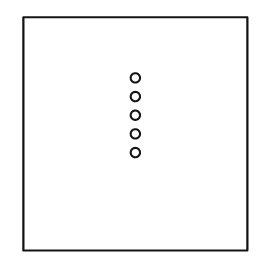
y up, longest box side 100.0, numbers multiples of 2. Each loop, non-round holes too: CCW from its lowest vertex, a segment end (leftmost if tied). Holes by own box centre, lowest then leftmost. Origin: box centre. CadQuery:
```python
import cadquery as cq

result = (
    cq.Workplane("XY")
    .moveTo(-48.0, -50.0)
    .lineTo(48.0, -50.0)
    .lineTo(48.0, 50.0)
    .lineTo(-48.0, 50.0)
    .close()
    .moveTo(0.0, -8.0)
    .circle(2.0)
    .moveTo(0.0, 0.0)
    .circle(2.0)
    .moveTo(0.0, 8.0)
    .circle(2.0)
    .moveTo(0.0, 16.0)
    .circle(2.0)
    .moveTo(0.0, 24.0)
    .circle(2.0)
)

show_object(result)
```